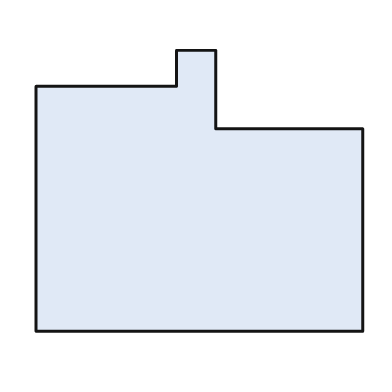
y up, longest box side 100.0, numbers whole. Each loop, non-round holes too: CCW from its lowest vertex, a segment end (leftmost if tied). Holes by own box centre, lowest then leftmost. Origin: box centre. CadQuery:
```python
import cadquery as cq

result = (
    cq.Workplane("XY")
    .moveTo(-50.0, -43.0)
    .lineTo(50.0, -43.0)
    .lineTo(50.0, 19.0)
    .lineTo(5.0, 19.0)
    .lineTo(5.0, 43.0)
    .lineTo(-7.0, 43.0)
    .lineTo(-7.0, 32.0)
    .lineTo(-50.0, 32.0)
    .close()
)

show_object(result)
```